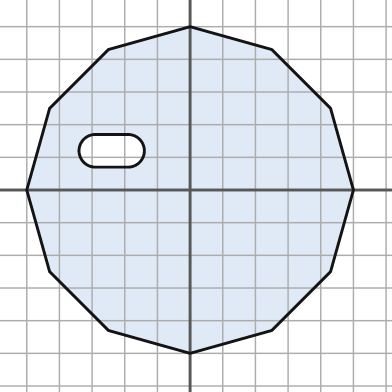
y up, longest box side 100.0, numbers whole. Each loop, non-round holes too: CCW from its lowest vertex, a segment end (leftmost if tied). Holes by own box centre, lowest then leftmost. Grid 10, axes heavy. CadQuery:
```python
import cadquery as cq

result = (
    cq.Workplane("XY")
    .moveTo(0.0, -50.0)
    .lineTo(25.0, -43.0)
    .lineTo(43.0, -25.0)
    .lineTo(50.0, 0.0)
    .lineTo(43.0, 25.0)
    .lineTo(25.0, 43.0)
    .lineTo(0.0, 50.0)
    .lineTo(-25.0, 43.0)
    .lineTo(-43.0, 25.0)
    .lineTo(-50.0, 0.0)
    .lineTo(-43.0, -25.0)
    .lineTo(-25.0, -43.0)
    .close()
    .moveTo(-29.0, 7.0)
    .lineTo(-19.0, 7.0)
    .threePointArc((-14.0, 12.0), (-19.0, 17.0))
    .lineTo(-29.0, 17.0)
    .threePointArc((-34.0, 12.0), (-29.0, 7.0))
    .close()
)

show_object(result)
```